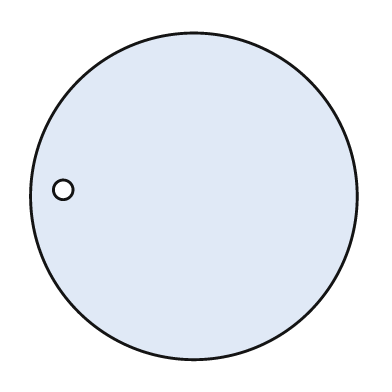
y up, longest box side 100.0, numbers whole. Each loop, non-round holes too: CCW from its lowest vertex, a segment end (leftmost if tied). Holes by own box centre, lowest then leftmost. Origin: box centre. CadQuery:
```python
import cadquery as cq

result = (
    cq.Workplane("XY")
    .moveTo(0.0, 0.0)
    .circle(50.0)
    .moveTo(-40.0, 2.0)
    .circle(3.0)
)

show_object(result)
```